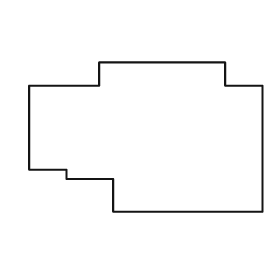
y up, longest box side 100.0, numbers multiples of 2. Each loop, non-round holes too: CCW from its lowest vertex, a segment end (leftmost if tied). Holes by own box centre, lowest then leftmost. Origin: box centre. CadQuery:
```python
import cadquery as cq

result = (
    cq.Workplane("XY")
    .moveTo(-14.0, -32.0)
    .lineTo(50.0, -32.0)
    .lineTo(50.0, 22.0)
    .lineTo(34.0, 22.0)
    .lineTo(34.0, 32.0)
    .lineTo(-20.0, 32.0)
    .lineTo(-20.0, 22.0)
    .lineTo(-50.0, 22.0)
    .lineTo(-50.0, -14.0)
    .lineTo(-34.0, -14.0)
    .lineTo(-34.0, -18.0)
    .lineTo(-14.0, -18.0)
    .close()
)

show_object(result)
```